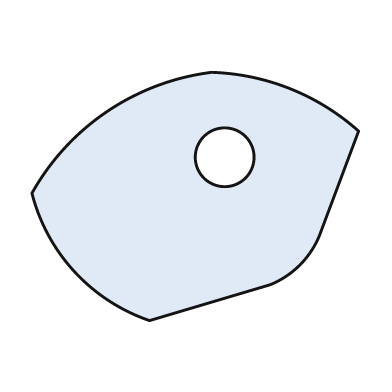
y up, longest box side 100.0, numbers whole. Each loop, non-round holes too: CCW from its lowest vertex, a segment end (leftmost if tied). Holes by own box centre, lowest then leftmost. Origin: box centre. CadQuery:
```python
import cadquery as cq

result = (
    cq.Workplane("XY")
    .moveTo(-14.0, -38.0)
    .lineTo(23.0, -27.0)
    .threePointArc((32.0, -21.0), (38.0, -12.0))
    .lineTo(50.0, 20.0)
    .threePointArc((29.0, 33.0), (5.0, 38.0))
    .threePointArc((-27.0, 26.0), (-50.0, 1.0))
    .threePointArc((-37.0, -23.0), (-14.0, -38.0))
    .close()
    .moveTo(9.0, 12.0)
    .circle(9.0)
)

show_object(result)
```